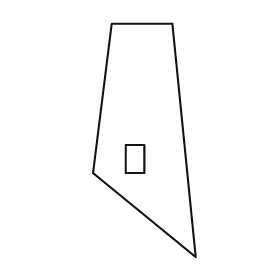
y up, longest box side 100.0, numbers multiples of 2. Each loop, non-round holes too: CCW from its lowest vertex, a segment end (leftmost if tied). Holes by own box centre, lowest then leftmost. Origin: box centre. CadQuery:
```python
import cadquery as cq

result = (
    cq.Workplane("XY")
    .moveTo(22.0, -50.0)
    .lineTo(12.0, 50.0)
    .lineTo(-14.0, 50.0)
    .lineTo(-22.0, -14.0)
    .close()
    .moveTo(-8.0, -14.0)
    .lineTo(0.0, -14.0)
    .lineTo(0.0, -2.0)
    .lineTo(-8.0, -2.0)
    .close()
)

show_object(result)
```